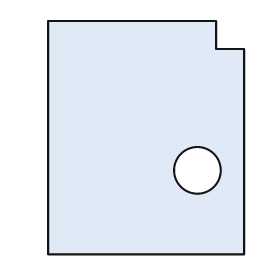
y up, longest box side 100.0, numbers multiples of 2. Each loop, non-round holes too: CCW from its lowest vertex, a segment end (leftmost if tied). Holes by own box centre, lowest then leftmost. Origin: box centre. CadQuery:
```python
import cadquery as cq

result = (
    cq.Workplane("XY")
    .moveTo(-42.0, -50.0)
    .lineTo(42.0, -50.0)
    .lineTo(42.0, 38.0)
    .lineTo(30.0, 38.0)
    .lineTo(30.0, 50.0)
    .lineTo(-42.0, 50.0)
    .close()
    .moveTo(22.0, -14.0)
    .circle(10.0)
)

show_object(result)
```